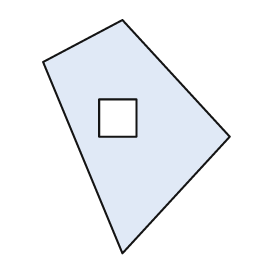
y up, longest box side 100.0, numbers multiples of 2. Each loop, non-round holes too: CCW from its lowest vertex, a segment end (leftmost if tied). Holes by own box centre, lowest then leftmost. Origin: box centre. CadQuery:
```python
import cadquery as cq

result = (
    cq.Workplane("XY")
    .moveTo(-6.0, -50.0)
    .lineTo(40.0, 0.0)
    .lineTo(-6.0, 50.0)
    .lineTo(-40.0, 32.0)
    .close()
    .moveTo(-16.0, 0.0)
    .lineTo(0.0, 0.0)
    .lineTo(0.0, 16.0)
    .lineTo(-16.0, 16.0)
    .close()
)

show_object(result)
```